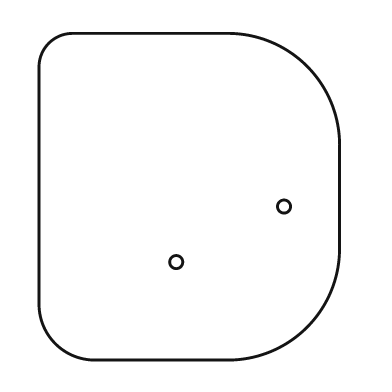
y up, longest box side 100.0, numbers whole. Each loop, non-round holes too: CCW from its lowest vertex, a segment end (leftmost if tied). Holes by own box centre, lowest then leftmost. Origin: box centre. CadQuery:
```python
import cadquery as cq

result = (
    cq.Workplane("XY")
    .moveTo(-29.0, -50.0)
    .lineTo(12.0, -50.0)
    .threePointArc((36.0, -40.0), (46.0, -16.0))
    .lineTo(46.0, 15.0)
    .threePointArc((36.0, 40.0), (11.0, 50.0))
    .lineTo(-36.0, 50.0)
    .threePointArc((-43.0, 47.0), (-46.0, 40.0))
    .lineTo(-46.0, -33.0)
    .threePointArc((-41.0, -45.0), (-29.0, -50.0))
    .close()
    .moveTo(-4.0, -20.0)
    .circle(2.0)
    .moveTo(29.0, -3.0)
    .circle(2.0)
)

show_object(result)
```